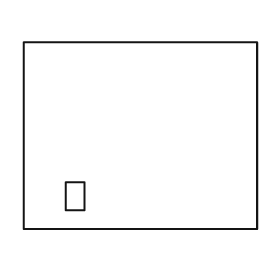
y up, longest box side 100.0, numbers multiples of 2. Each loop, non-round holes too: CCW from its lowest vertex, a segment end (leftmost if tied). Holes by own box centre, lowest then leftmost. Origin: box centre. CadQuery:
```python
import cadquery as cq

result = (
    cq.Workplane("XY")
    .moveTo(-50.0, -40.0)
    .lineTo(50.0, -40.0)
    .lineTo(50.0, 40.0)
    .lineTo(-50.0, 40.0)
    .close()
    .moveTo(-32.0, -32.0)
    .lineTo(-24.0, -32.0)
    .lineTo(-24.0, -20.0)
    .lineTo(-32.0, -20.0)
    .close()
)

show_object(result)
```